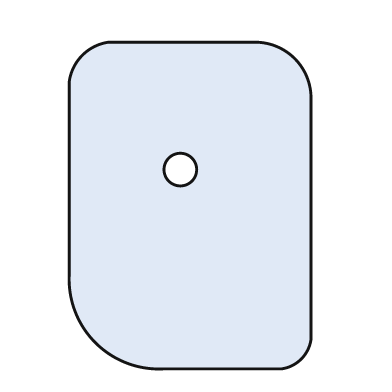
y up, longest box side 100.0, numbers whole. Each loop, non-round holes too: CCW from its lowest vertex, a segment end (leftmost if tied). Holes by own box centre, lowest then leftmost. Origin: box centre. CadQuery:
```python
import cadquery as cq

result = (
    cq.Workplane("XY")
    .moveTo(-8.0, -50.0)
    .lineTo(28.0, -50.0)
    .threePointArc((34.0, -47.0), (37.0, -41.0))
    .lineTo(37.0, 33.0)
    .threePointArc((32.0, 45.0), (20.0, 50.0))
    .lineTo(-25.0, 50.0)
    .threePointArc((-33.0, 46.0), (-37.0, 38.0))
    .lineTo(-37.0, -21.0)
    .threePointArc((-29.0, -42.0), (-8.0, -50.0))
    .close()
    .moveTo(-3.0, 11.0)
    .circle(5.0)
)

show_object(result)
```